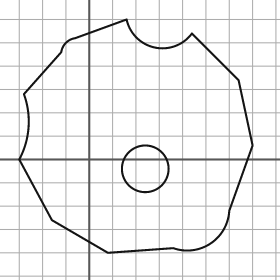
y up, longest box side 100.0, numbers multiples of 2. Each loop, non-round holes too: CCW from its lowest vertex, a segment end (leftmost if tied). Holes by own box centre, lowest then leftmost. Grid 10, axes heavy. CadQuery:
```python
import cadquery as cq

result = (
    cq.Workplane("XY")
    .moveTo(8.0, -40.0)
    .lineTo(36.0, -38.0)
    .threePointArc((52.0, -36.0), (60.0, -22.0))
    .lineTo(70.0, 6.0)
    .lineTo(64.0, 34.0)
    .lineTo(44.0, 54.0)
    .threePointArc((28.0, 48.0), (16.0, 60.0))
    .lineTo(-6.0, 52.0)
    .threePointArc((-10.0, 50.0), (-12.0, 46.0))
    .lineTo(-28.0, 28.0)
    .threePointArc((-26.0, 14.0), (-30.0, 0.0))
    .lineTo(-16.0, -26.0)
    .close()
    .moveTo(24.0, -4.0)
    .circle(10.0)
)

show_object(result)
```